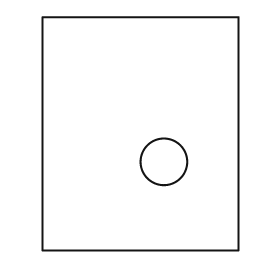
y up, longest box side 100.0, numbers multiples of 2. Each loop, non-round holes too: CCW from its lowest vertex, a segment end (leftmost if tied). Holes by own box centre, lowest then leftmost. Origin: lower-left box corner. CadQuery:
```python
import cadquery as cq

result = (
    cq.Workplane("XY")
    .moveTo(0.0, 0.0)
    .lineTo(84.0, 0.0)
    .lineTo(84.0, 100.0)
    .lineTo(0.0, 100.0)
    .close()
    .moveTo(52.0, 38.0)
    .circle(10.0)
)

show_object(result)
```